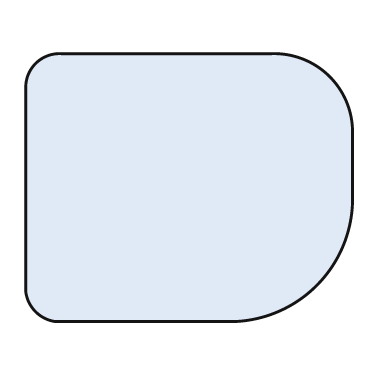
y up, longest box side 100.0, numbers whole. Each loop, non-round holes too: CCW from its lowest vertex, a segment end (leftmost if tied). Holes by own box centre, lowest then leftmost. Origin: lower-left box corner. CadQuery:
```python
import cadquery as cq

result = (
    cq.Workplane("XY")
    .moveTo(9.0, 0.0)
    .lineTo(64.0, 0.0)
    .threePointArc((89.0, 11.0), (100.0, 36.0))
    .lineTo(100.0, 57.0)
    .threePointArc((93.0, 75.0), (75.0, 82.0))
    .lineTo(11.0, 82.0)
    .threePointArc((3.0, 79.0), (0.0, 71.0))
    .lineTo(0.0, 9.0)
    .threePointArc((3.0, 3.0), (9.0, 0.0))
    .close()
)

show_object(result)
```